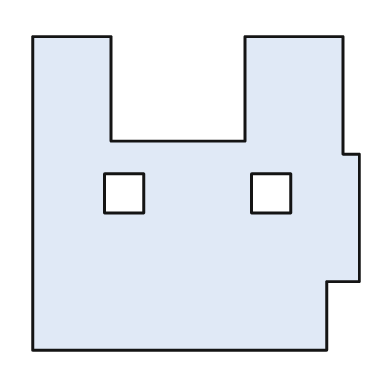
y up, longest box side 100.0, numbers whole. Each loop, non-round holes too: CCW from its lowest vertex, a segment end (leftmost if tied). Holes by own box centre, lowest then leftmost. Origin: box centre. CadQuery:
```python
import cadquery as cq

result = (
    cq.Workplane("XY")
    .moveTo(-50.0, -48.0)
    .lineTo(40.0, -48.0)
    .lineTo(40.0, -27.0)
    .lineTo(50.0, -27.0)
    .lineTo(50.0, 12.0)
    .lineTo(45.0, 12.0)
    .lineTo(45.0, 48.0)
    .lineTo(15.0, 48.0)
    .lineTo(15.0, 16.0)
    .lineTo(-26.0, 16.0)
    .lineTo(-26.0, 48.0)
    .lineTo(-50.0, 48.0)
    .close()
    .moveTo(-28.0, -6.0)
    .lineTo(-16.0, -6.0)
    .lineTo(-16.0, 6.0)
    .lineTo(-28.0, 6.0)
    .close()
    .moveTo(17.0, -6.0)
    .lineTo(29.0, -6.0)
    .lineTo(29.0, 6.0)
    .lineTo(17.0, 6.0)
    .close()
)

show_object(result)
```